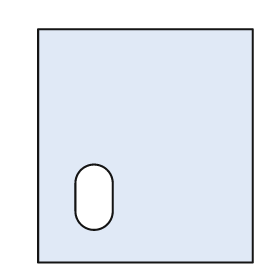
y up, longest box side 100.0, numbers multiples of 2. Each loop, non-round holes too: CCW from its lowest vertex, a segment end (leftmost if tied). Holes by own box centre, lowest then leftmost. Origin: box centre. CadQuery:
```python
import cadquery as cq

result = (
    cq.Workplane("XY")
    .moveTo(-46.0, -50.0)
    .lineTo(46.0, -50.0)
    .lineTo(46.0, 50.0)
    .lineTo(-46.0, 50.0)
    .close()
    .moveTo(-30.0, -28.0)
    .threePointArc((-22.0, -36.0), (-14.0, -28.0))
    .lineTo(-14.0, -16.0)
    .threePointArc((-22.0, -8.0), (-30.0, -16.0))
    .close()
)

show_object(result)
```